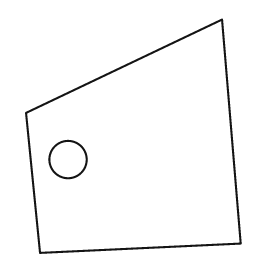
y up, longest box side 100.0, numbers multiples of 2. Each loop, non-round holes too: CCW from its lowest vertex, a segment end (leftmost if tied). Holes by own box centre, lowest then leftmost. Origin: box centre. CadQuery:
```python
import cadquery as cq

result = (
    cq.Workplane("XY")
    .moveTo(-40.0, -50.0)
    .lineTo(46.0, -46.0)
    .lineTo(38.0, 50.0)
    .lineTo(-46.0, 10.0)
    .close()
    .moveTo(-28.0, -10.0)
    .circle(8.0)
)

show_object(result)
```